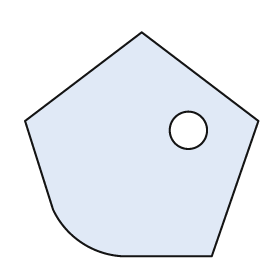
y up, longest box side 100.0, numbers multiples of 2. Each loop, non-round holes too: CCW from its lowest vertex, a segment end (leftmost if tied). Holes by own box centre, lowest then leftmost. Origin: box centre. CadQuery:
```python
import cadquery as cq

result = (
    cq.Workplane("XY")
    .moveTo(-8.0, -48.0)
    .lineTo(30.0, -48.0)
    .lineTo(50.0, 10.0)
    .lineTo(0.0, 48.0)
    .lineTo(-50.0, 10.0)
    .lineTo(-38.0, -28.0)
    .threePointArc((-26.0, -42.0), (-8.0, -48.0))
    .close()
    .moveTo(20.0, 6.0)
    .circle(8.0)
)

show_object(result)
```